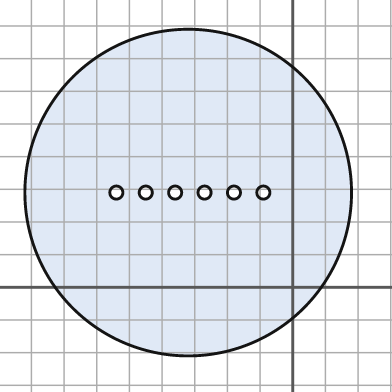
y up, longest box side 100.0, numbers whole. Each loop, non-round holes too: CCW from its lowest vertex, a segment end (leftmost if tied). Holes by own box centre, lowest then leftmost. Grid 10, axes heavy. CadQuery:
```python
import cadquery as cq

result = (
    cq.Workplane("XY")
    .moveTo(-32.0, 29.0)
    .circle(50.0)
    .moveTo(-54.0, 29.0)
    .circle(2.0)
    .moveTo(-45.0, 29.0)
    .circle(2.0)
    .moveTo(-36.0, 29.0)
    .circle(2.0)
    .moveTo(-27.0, 29.0)
    .circle(2.0)
    .moveTo(-18.0, 29.0)
    .circle(2.0)
    .moveTo(-9.0, 29.0)
    .circle(2.0)
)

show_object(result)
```